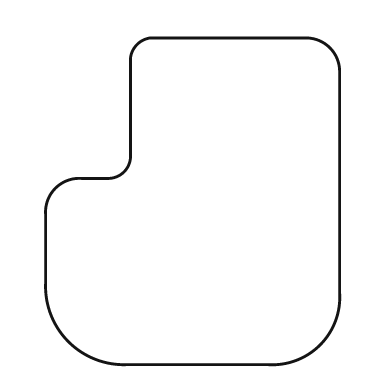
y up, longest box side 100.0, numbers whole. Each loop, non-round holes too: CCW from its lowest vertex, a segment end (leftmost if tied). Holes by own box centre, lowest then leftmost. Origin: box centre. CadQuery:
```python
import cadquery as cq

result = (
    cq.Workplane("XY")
    .moveTo(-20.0, -50.0)
    .lineTo(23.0, -50.0)
    .threePointArc((39.0, -44.0), (45.0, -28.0))
    .lineTo(45.0, 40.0)
    .threePointArc((42.0, 47.0), (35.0, 50.0))
    .lineTo(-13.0, 50.0)
    .threePointArc((-17.0, 48.0), (-19.0, 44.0))
    .lineTo(-19.0, 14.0)
    .threePointArc((-21.0, 9.0), (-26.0, 7.0))
    .lineTo(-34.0, 7.0)
    .threePointArc((-42.0, 4.0), (-45.0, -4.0))
    .lineTo(-45.0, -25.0)
    .threePointArc((-38.0, -43.0), (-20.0, -50.0))
    .close()
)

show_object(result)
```